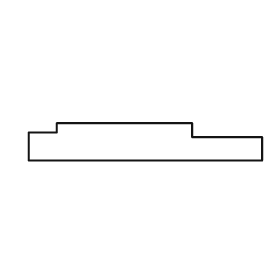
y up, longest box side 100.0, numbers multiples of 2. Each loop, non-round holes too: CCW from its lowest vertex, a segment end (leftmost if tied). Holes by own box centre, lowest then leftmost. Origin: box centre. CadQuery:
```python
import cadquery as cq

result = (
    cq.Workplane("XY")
    .moveTo(-50.0, -8.0)
    .lineTo(50.0, -8.0)
    .lineTo(50.0, 2.0)
    .lineTo(20.0, 2.0)
    .lineTo(20.0, 8.0)
    .lineTo(-38.0, 8.0)
    .lineTo(-38.0, 4.0)
    .lineTo(-50.0, 4.0)
    .close()
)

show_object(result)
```